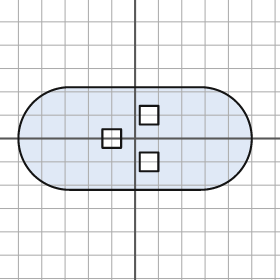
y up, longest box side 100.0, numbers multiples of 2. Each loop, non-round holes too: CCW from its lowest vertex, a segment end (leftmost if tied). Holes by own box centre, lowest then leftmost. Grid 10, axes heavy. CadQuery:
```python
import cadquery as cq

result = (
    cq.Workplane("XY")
    .moveTo(-28.0, -22.0)
    .lineTo(28.0, -22.0)
    .threePointArc((50.0, 0.0), (28.0, 22.0))
    .lineTo(-28.0, 22.0)
    .threePointArc((-50.0, 0.0), (-28.0, -22.0))
    .close()
    .moveTo(2.0, -14.0)
    .lineTo(10.0, -14.0)
    .lineTo(10.0, -6.0)
    .lineTo(2.0, -6.0)
    .close()
    .moveTo(-14.0, -4.0)
    .lineTo(-6.0, -4.0)
    .lineTo(-6.0, 4.0)
    .lineTo(-14.0, 4.0)
    .close()
    .moveTo(2.0, 6.0)
    .lineTo(10.0, 6.0)
    .lineTo(10.0, 14.0)
    .lineTo(2.0, 14.0)
    .close()
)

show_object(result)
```